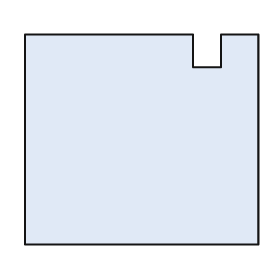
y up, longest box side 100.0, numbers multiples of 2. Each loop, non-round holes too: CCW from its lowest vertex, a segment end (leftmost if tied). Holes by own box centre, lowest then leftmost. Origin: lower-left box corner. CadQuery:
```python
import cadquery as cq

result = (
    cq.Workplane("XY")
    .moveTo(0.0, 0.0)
    .lineTo(100.0, 0.0)
    .lineTo(100.0, 90.0)
    .lineTo(84.0, 90.0)
    .lineTo(84.0, 76.0)
    .lineTo(72.0, 76.0)
    .lineTo(72.0, 90.0)
    .lineTo(0.0, 90.0)
    .close()
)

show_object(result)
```